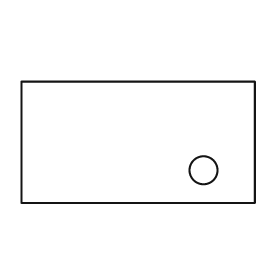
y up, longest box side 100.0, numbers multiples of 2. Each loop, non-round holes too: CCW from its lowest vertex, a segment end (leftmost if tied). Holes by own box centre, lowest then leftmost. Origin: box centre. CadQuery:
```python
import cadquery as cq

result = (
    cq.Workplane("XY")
    .moveTo(-50.0, -26.0)
    .lineTo(50.0, -26.0)
    .lineTo(50.0, 26.0)
    .lineTo(-50.0, 26.0)
    .close()
    .moveTo(28.0, -12.0)
    .circle(6.0)
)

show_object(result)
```